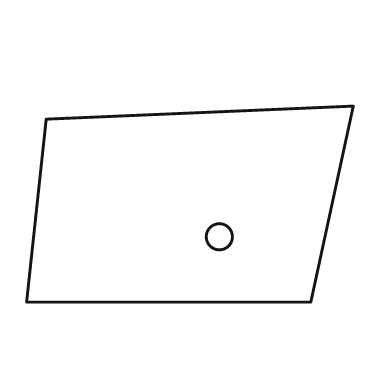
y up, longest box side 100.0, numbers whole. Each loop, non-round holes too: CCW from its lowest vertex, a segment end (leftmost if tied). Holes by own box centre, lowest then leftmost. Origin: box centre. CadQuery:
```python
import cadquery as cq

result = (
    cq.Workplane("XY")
    .moveTo(-50.0, -30.0)
    .lineTo(37.0, -30.0)
    .lineTo(50.0, 30.0)
    .lineTo(-44.0, 26.0)
    .close()
    .moveTo(9.0, -10.0)
    .circle(4.0)
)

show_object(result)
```